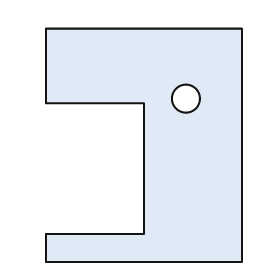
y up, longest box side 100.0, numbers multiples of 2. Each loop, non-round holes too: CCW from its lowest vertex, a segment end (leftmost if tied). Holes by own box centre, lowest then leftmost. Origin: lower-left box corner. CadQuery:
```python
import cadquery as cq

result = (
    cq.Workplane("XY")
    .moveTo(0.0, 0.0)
    .lineTo(84.0, 0.0)
    .lineTo(84.0, 100.0)
    .lineTo(0.0, 100.0)
    .lineTo(0.0, 68.0)
    .lineTo(42.0, 68.0)
    .lineTo(42.0, 12.0)
    .lineTo(0.0, 12.0)
    .close()
    .moveTo(60.0, 70.0)
    .circle(6.0)
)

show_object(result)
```